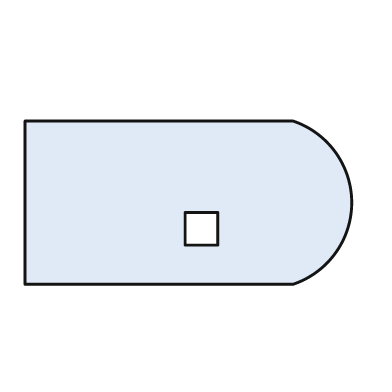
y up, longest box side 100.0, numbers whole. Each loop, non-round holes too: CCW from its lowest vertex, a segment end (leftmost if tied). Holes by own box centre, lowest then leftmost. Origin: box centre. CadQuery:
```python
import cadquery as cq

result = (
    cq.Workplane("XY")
    .moveTo(-50.0, -25.0)
    .lineTo(32.0, -25.0)
    .threePointArc((50.0, 0.0), (32.0, 25.0))
    .lineTo(-50.0, 25.0)
    .close()
    .moveTo(-1.0, -13.0)
    .lineTo(9.0, -13.0)
    .lineTo(9.0, -3.0)
    .lineTo(-1.0, -3.0)
    .close()
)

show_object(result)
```